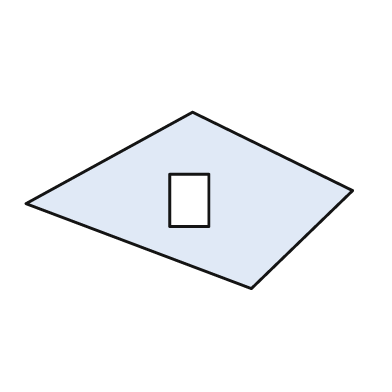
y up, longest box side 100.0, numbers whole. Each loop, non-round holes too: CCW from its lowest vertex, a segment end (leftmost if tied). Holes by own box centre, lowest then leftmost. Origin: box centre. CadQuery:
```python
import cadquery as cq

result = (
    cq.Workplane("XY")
    .moveTo(19.0, -27.0)
    .lineTo(50.0, 3.0)
    .lineTo(1.0, 27.0)
    .lineTo(-50.0, -1.0)
    .close()
    .moveTo(-6.0, -8.0)
    .lineTo(6.0, -8.0)
    .lineTo(6.0, 8.0)
    .lineTo(-6.0, 8.0)
    .close()
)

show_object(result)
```